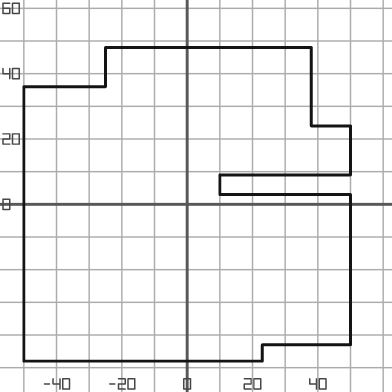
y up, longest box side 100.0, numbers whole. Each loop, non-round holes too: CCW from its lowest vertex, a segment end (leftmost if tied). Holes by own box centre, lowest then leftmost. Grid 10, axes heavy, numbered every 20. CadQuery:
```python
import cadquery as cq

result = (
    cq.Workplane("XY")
    .moveTo(-50.0, -48.0)
    .lineTo(23.0, -48.0)
    .lineTo(23.0, -43.0)
    .lineTo(50.0, -43.0)
    .lineTo(50.0, 3.0)
    .lineTo(10.0, 3.0)
    .lineTo(10.0, 9.0)
    .lineTo(50.0, 9.0)
    .lineTo(50.0, 24.0)
    .lineTo(38.0, 24.0)
    .lineTo(38.0, 48.0)
    .lineTo(-25.0, 48.0)
    .lineTo(-25.0, 36.0)
    .lineTo(-50.0, 36.0)
    .close()
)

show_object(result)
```